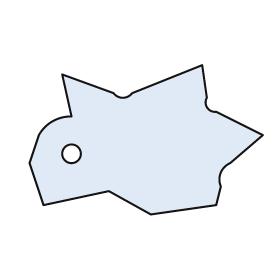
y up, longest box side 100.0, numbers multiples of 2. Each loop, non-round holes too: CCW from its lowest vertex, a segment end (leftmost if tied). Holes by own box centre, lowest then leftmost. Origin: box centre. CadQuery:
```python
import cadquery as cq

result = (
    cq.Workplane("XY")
    .moveTo(2.0, -32.0)
    .lineTo(30.0, -28.0)
    .lineTo(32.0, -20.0)
    .threePointArc((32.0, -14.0), (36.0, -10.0))
    .lineTo(50.0, 2.0)
    .lineTo(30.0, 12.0)
    .threePointArc((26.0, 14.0), (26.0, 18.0))
    .lineTo(24.0, 32.0)
    .lineTo(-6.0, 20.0)
    .threePointArc((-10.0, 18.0), (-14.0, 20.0))
    .lineTo(-36.0, 28.0)
    .lineTo(-32.0, 10.0)
    .threePointArc((-40.0, 8.0), (-46.0, 2.0))
    .lineTo(-50.0, -10.0)
    .lineTo(-44.0, -28.0)
    .lineTo(-16.0, -22.0)
    .close()
    .moveTo(-32.0, -6.0)
    .circle(4.0)
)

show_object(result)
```